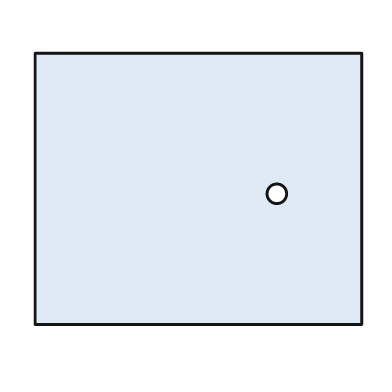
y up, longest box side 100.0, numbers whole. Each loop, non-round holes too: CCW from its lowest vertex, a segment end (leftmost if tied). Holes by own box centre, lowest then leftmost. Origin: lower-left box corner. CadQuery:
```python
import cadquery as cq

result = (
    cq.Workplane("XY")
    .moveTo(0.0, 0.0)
    .lineTo(100.0, 0.0)
    .lineTo(100.0, 83.0)
    .lineTo(0.0, 83.0)
    .close()
    .moveTo(74.0, 40.0)
    .circle(3.0)
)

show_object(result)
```